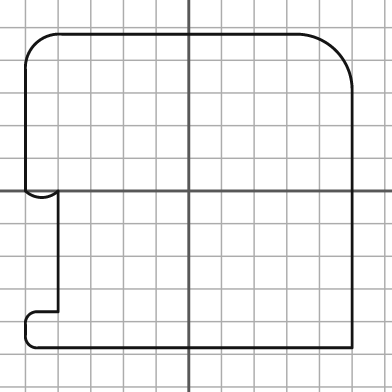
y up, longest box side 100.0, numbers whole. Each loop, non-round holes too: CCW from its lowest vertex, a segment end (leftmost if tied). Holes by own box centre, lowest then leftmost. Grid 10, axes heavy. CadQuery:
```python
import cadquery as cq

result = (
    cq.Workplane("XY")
    .moveTo(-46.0, -48.0)
    .lineTo(50.0, -48.0)
    .lineTo(50.0, 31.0)
    .threePointArc((45.0, 43.0), (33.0, 48.0))
    .lineTo(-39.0, 48.0)
    .threePointArc((-47.0, 45.0), (-50.0, 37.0))
    .lineTo(-50.0, 0.0)
    .threePointArc((-45.0, -2.0), (-40.0, 0.0))
    .lineTo(-40.0, -37.0)
    .lineTo(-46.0, -37.0)
    .threePointArc((-49.0, -38.0), (-50.0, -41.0))
    .lineTo(-50.0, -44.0)
    .threePointArc((-49.0, -47.0), (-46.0, -48.0))
    .close()
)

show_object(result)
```